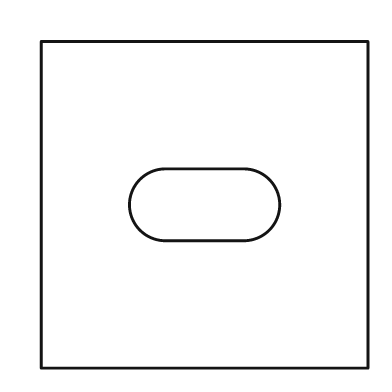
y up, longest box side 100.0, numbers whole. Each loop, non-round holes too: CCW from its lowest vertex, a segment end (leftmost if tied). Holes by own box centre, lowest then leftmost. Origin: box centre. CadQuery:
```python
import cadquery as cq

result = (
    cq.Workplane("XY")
    .moveTo(-50.0, -50.0)
    .lineTo(50.0, -50.0)
    .lineTo(50.0, 50.0)
    .lineTo(-50.0, 50.0)
    .close()
    .moveTo(-12.0, -11.0)
    .lineTo(12.0, -11.0)
    .threePointArc((23.0, 0.0), (12.0, 11.0))
    .lineTo(-12.0, 11.0)
    .threePointArc((-23.0, 0.0), (-12.0, -11.0))
    .close()
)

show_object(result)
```